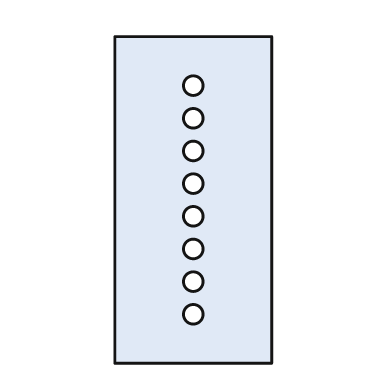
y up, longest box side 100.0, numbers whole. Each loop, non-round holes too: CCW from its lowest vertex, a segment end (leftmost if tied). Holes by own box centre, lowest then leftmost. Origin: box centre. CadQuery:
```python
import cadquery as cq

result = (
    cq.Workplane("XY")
    .moveTo(-24.0, -50.0)
    .lineTo(24.0, -50.0)
    .lineTo(24.0, 50.0)
    .lineTo(-24.0, 50.0)
    .close()
    .moveTo(0.0, -35.0)
    .circle(3.0)
    .moveTo(0.0, -25.0)
    .circle(3.0)
    .moveTo(0.0, -15.0)
    .circle(3.0)
    .moveTo(0.0, -5.0)
    .circle(3.0)
    .moveTo(0.0, 5.0)
    .circle(3.0)
    .moveTo(0.0, 15.0)
    .circle(3.0)
    .moveTo(0.0, 25.0)
    .circle(3.0)
    .moveTo(0.0, 35.0)
    .circle(3.0)
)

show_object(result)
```